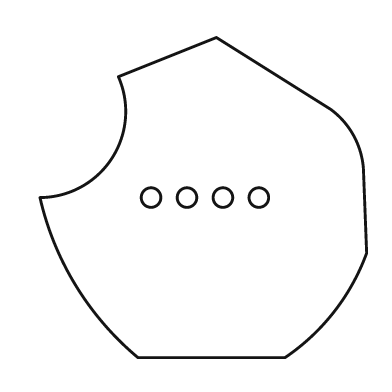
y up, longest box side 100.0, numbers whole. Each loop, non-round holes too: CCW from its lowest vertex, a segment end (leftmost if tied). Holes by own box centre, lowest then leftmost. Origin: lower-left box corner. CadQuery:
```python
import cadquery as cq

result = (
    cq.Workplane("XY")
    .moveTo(30.0, 0.0)
    .lineTo(75.0, 0.0)
    .threePointArc((90.0, 14.0), (100.0, 32.0))
    .lineTo(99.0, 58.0)
    .threePointArc((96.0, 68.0), (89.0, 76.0))
    .lineTo(54.0, 98.0)
    .lineTo(24.0, 86.0)
    .threePointArc((22.0, 61.0), (0.0, 49.0))
    .threePointArc((11.0, 22.0), (30.0, 0.0))
    .close()
    .moveTo(34.0, 49.0)
    .circle(3.0)
    .moveTo(45.0, 49.0)
    .circle(3.0)
    .moveTo(56.0, 49.0)
    .circle(3.0)
    .moveTo(67.0, 49.0)
    .circle(3.0)
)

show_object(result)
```